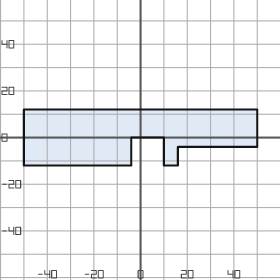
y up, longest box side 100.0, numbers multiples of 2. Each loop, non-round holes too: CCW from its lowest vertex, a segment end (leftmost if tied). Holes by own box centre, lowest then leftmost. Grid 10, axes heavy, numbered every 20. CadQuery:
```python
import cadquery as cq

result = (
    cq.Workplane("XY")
    .moveTo(-50.0, -12.0)
    .lineTo(-4.0, -12.0)
    .lineTo(-4.0, 0.0)
    .lineTo(10.0, 0.0)
    .lineTo(10.0, -12.0)
    .lineTo(16.0, -12.0)
    .lineTo(16.0, -4.0)
    .lineTo(50.0, -4.0)
    .lineTo(50.0, 12.0)
    .lineTo(-50.0, 12.0)
    .close()
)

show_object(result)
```